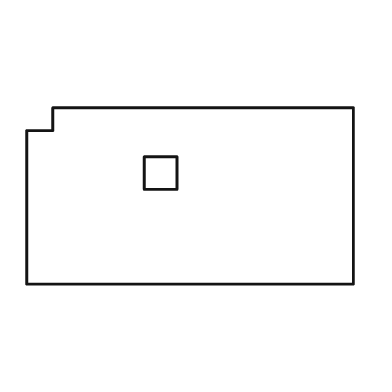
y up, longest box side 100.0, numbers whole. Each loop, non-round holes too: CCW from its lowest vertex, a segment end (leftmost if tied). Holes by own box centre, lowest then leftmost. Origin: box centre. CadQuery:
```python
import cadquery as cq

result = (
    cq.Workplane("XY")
    .moveTo(-50.0, -27.0)
    .lineTo(50.0, -27.0)
    .lineTo(50.0, 27.0)
    .lineTo(-42.0, 27.0)
    .lineTo(-42.0, 20.0)
    .lineTo(-50.0, 20.0)
    .close()
    .moveTo(-14.0, 2.0)
    .lineTo(-4.0, 2.0)
    .lineTo(-4.0, 12.0)
    .lineTo(-14.0, 12.0)
    .close()
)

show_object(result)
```